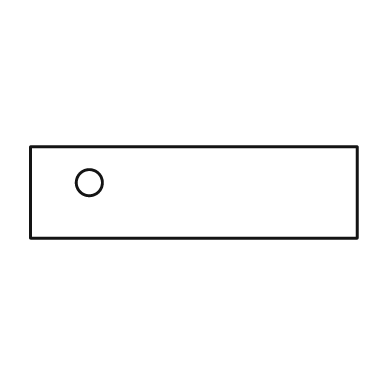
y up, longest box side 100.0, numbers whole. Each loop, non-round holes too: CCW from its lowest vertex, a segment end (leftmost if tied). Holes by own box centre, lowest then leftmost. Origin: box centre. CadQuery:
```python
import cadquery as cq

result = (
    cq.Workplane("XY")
    .moveTo(-50.0, -14.0)
    .lineTo(50.0, -14.0)
    .lineTo(50.0, 14.0)
    .lineTo(-50.0, 14.0)
    .close()
    .moveTo(-32.0, 3.0)
    .circle(4.0)
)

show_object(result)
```